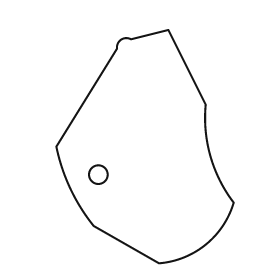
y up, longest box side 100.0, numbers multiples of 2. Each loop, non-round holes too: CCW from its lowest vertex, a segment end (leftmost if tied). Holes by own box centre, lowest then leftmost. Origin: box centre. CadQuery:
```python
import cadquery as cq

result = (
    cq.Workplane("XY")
    .moveTo(6.0, -50.0)
    .threePointArc((26.0, -42.0), (38.0, -24.0))
    .threePointArc((28.0, -4.0), (26.0, 18.0))
    .lineTo(10.0, 50.0)
    .lineTo(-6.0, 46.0)
    .threePointArc((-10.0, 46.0), (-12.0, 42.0))
    .lineTo(-38.0, 0.0)
    .threePointArc((-32.0, -18.0), (-22.0, -34.0))
    .close()
    .moveTo(-20.0, -12.0)
    .circle(4.0)
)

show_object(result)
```